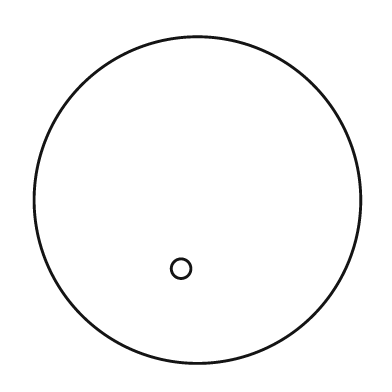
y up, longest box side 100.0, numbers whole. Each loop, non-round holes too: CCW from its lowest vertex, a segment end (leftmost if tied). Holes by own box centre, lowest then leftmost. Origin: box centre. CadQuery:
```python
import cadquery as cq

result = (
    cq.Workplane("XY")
    .moveTo(0.0, 0.0)
    .circle(50.0)
    .moveTo(-5.0, -21.0)
    .circle(3.0)
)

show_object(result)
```